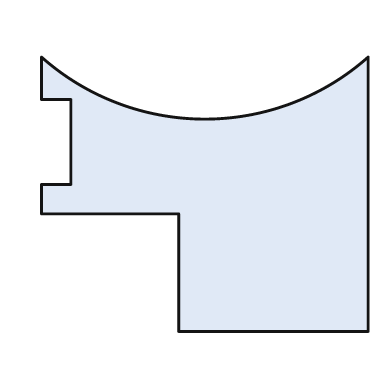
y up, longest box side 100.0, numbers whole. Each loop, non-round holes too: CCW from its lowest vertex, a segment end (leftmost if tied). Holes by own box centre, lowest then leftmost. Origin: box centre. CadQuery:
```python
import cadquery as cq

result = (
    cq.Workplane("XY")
    .moveTo(-8.0, -42.0)
    .lineTo(50.0, -42.0)
    .lineTo(50.0, 42.0)
    .threePointArc((0.0, 23.0), (-50.0, 42.0))
    .lineTo(-50.0, 29.0)
    .lineTo(-41.0, 29.0)
    .lineTo(-41.0, 3.0)
    .lineTo(-50.0, 3.0)
    .lineTo(-50.0, -6.0)
    .lineTo(-8.0, -6.0)
    .close()
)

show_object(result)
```